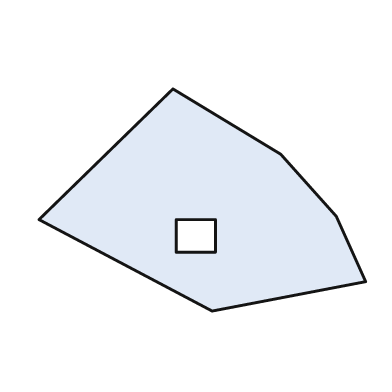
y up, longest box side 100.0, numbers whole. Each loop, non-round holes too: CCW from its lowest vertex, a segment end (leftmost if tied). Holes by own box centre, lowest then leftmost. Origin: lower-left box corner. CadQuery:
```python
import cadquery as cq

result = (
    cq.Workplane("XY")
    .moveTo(53.0, 0.0)
    .lineTo(100.0, 9.0)
    .lineTo(91.0, 29.0)
    .lineTo(74.0, 48.0)
    .lineTo(41.0, 68.0)
    .lineTo(0.0, 28.0)
    .close()
    .moveTo(42.0, 18.0)
    .lineTo(54.0, 18.0)
    .lineTo(54.0, 28.0)
    .lineTo(42.0, 28.0)
    .close()
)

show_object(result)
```